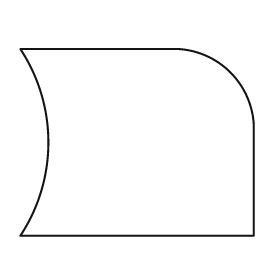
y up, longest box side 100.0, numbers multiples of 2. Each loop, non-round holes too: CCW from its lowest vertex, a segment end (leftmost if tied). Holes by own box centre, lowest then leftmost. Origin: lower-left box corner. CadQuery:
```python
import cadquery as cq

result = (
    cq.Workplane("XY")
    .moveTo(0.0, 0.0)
    .lineTo(100.0, 0.0)
    .lineTo(100.0, 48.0)
    .threePointArc((90.0, 70.0), (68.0, 80.0))
    .lineTo(0.0, 80.0)
    .threePointArc((12.0, 40.0), (0.0, 0.0))
    .close()
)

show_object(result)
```